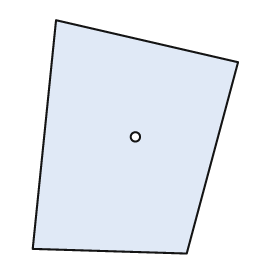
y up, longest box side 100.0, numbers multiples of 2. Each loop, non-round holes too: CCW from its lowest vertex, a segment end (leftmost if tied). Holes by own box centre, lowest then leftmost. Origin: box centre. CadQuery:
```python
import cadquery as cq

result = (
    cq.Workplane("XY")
    .moveTo(22.0, -50.0)
    .lineTo(44.0, 32.0)
    .lineTo(-34.0, 50.0)
    .lineTo(-44.0, -48.0)
    .close()
    .moveTo(0.0, 0.0)
    .circle(2.0)
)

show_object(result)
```